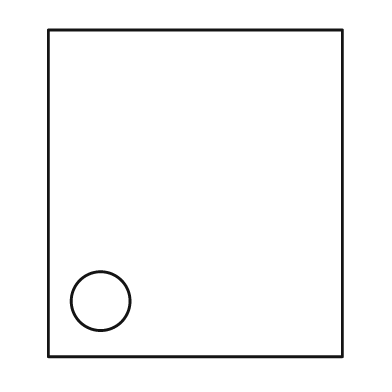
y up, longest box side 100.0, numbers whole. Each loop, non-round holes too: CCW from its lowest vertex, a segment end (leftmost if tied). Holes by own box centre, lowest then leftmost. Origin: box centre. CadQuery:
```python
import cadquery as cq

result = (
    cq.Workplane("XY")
    .moveTo(-45.0, -50.0)
    .lineTo(45.0, -50.0)
    .lineTo(45.0, 50.0)
    .lineTo(-45.0, 50.0)
    .close()
    .moveTo(-29.0, -33.0)
    .circle(9.0)
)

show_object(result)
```